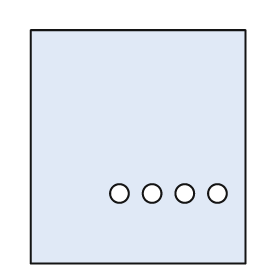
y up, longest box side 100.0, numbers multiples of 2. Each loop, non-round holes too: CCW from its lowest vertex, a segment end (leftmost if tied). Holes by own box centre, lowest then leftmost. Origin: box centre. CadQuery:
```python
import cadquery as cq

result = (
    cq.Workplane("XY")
    .moveTo(-46.0, -50.0)
    .lineTo(46.0, -50.0)
    .lineTo(46.0, 50.0)
    .lineTo(-46.0, 50.0)
    .close()
    .moveTo(-8.0, -20.0)
    .circle(4.0)
    .moveTo(6.0, -20.0)
    .circle(4.0)
    .moveTo(20.0, -20.0)
    .circle(4.0)
    .moveTo(34.0, -20.0)
    .circle(4.0)
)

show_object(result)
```